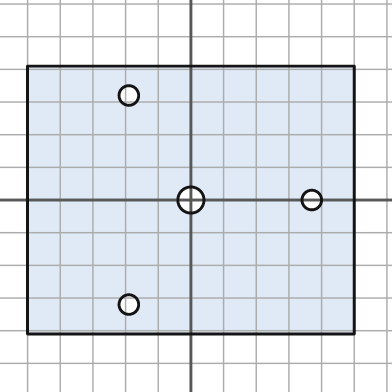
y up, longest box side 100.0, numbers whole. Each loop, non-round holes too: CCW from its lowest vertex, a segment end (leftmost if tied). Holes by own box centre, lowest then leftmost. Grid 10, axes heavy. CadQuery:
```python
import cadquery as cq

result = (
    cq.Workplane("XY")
    .moveTo(-50.0, -41.0)
    .lineTo(50.0, -41.0)
    .lineTo(50.0, 41.0)
    .lineTo(-50.0, 41.0)
    .close()
    .moveTo(-19.0, -32.0)
    .circle(3.0)
    .moveTo(0.0, 0.0)
    .circle(4.0)
    .moveTo(37.0, 0.0)
    .circle(3.0)
    .moveTo(-19.0, 32.0)
    .circle(3.0)
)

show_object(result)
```